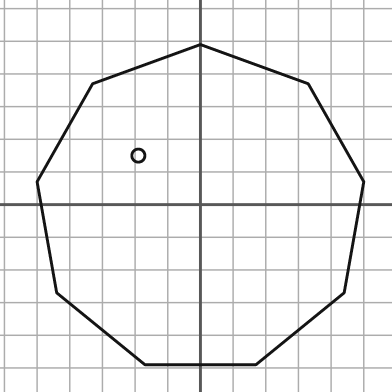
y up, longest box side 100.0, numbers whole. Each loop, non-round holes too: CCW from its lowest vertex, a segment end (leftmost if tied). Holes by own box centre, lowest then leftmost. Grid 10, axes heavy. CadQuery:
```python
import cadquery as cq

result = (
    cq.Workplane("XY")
    .moveTo(-17.0, -49.0)
    .lineTo(17.0, -49.0)
    .lineTo(44.0, -27.0)
    .lineTo(50.0, 7.0)
    .lineTo(33.0, 37.0)
    .lineTo(0.0, 49.0)
    .lineTo(-33.0, 37.0)
    .lineTo(-50.0, 7.0)
    .lineTo(-44.0, -27.0)
    .close()
    .moveTo(-19.0, 15.0)
    .circle(2.0)
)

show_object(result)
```